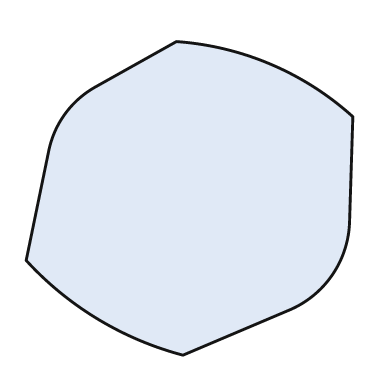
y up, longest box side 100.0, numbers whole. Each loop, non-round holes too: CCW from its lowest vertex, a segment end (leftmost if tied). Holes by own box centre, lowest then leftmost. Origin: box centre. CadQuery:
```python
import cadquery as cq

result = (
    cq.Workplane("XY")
    .moveTo(-2.0, -48.0)
    .lineTo(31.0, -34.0)
    .threePointArc((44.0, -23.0), (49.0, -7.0))
    .lineTo(50.0, 25.0)
    .threePointArc((25.0, 41.0), (-4.0, 48.0))
    .lineTo(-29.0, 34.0)
    .threePointArc((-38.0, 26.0), (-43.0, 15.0))
    .lineTo(-50.0, -19.0)
    .threePointArc((-28.0, -37.0), (-2.0, -48.0))
    .close()
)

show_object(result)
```